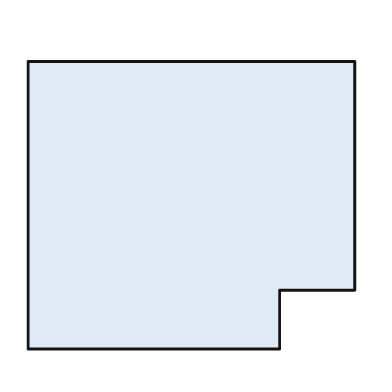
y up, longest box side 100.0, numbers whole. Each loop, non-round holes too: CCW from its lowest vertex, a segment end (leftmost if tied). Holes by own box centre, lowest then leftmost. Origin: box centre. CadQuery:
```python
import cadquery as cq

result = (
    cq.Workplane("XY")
    .moveTo(-50.0, -44.0)
    .lineTo(27.0, -44.0)
    .lineTo(27.0, -26.0)
    .lineTo(50.0, -26.0)
    .lineTo(50.0, 44.0)
    .lineTo(-50.0, 44.0)
    .close()
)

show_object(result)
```